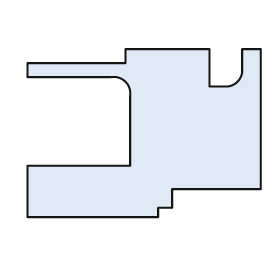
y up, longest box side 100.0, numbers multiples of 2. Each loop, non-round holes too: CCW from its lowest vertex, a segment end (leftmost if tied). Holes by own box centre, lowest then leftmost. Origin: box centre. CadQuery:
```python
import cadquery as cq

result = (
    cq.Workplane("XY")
    .moveTo(-50.0, -36.0)
    .lineTo(6.0, -36.0)
    .lineTo(6.0, -32.0)
    .lineTo(12.0, -32.0)
    .lineTo(12.0, -24.0)
    .lineTo(50.0, -24.0)
    .lineTo(50.0, 36.0)
    .lineTo(42.0, 36.0)
    .lineTo(42.0, 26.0)
    .threePointArc((40.0, 22.0), (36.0, 20.0))
    .lineTo(28.0, 20.0)
    .lineTo(28.0, 36.0)
    .lineTo(-8.0, 36.0)
    .lineTo(-8.0, 30.0)
    .lineTo(-50.0, 30.0)
    .lineTo(-50.0, 24.0)
    .lineTo(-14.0, 24.0)
    .threePointArc((-8.0, 22.0), (-6.0, 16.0))
    .lineTo(-6.0, -14.0)
    .lineTo(-50.0, -14.0)
    .close()
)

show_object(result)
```